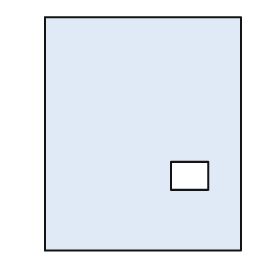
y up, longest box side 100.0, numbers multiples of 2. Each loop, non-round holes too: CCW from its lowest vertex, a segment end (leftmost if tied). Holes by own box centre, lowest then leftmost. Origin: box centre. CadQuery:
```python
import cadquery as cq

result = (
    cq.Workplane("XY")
    .moveTo(-42.0, -50.0)
    .lineTo(42.0, -50.0)
    .lineTo(42.0, 50.0)
    .lineTo(-42.0, 50.0)
    .close()
    .moveTo(12.0, -24.0)
    .lineTo(28.0, -24.0)
    .lineTo(28.0, -12.0)
    .lineTo(12.0, -12.0)
    .close()
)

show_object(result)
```